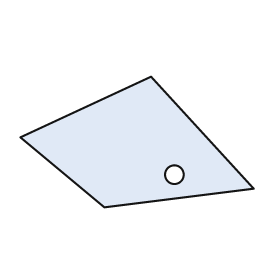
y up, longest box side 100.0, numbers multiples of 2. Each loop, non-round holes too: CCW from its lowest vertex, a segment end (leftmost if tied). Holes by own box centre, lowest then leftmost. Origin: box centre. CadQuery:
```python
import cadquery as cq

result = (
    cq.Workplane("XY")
    .moveTo(-14.0, -28.0)
    .lineTo(50.0, -20.0)
    .lineTo(6.0, 28.0)
    .lineTo(-50.0, 2.0)
    .close()
    .moveTo(16.0, -14.0)
    .circle(4.0)
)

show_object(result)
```